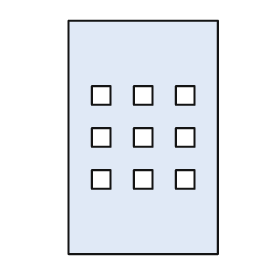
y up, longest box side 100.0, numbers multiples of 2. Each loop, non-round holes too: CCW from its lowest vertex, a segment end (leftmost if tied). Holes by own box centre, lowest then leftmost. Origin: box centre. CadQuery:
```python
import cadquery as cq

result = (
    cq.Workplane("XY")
    .moveTo(-32.0, -50.0)
    .lineTo(32.0, -50.0)
    .lineTo(32.0, 50.0)
    .lineTo(-32.0, 50.0)
    .close()
    .moveTo(-22.0, -22.0)
    .lineTo(-14.0, -22.0)
    .lineTo(-14.0, -14.0)
    .lineTo(-22.0, -14.0)
    .close()
    .moveTo(-4.0, -22.0)
    .lineTo(4.0, -22.0)
    .lineTo(4.0, -14.0)
    .lineTo(-4.0, -14.0)
    .close()
    .moveTo(14.0, -22.0)
    .lineTo(22.0, -22.0)
    .lineTo(22.0, -14.0)
    .lineTo(14.0, -14.0)
    .close()
    .moveTo(-22.0, -4.0)
    .lineTo(-14.0, -4.0)
    .lineTo(-14.0, 4.0)
    .lineTo(-22.0, 4.0)
    .close()
    .moveTo(-4.0, -4.0)
    .lineTo(4.0, -4.0)
    .lineTo(4.0, 4.0)
    .lineTo(-4.0, 4.0)
    .close()
    .moveTo(14.0, -4.0)
    .lineTo(22.0, -4.0)
    .lineTo(22.0, 4.0)
    .lineTo(14.0, 4.0)
    .close()
    .moveTo(-22.0, 14.0)
    .lineTo(-14.0, 14.0)
    .lineTo(-14.0, 22.0)
    .lineTo(-22.0, 22.0)
    .close()
    .moveTo(-4.0, 14.0)
    .lineTo(4.0, 14.0)
    .lineTo(4.0, 22.0)
    .lineTo(-4.0, 22.0)
    .close()
    .moveTo(14.0, 14.0)
    .lineTo(22.0, 14.0)
    .lineTo(22.0, 22.0)
    .lineTo(14.0, 22.0)
    .close()
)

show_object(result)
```